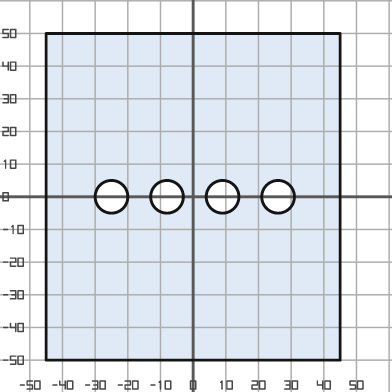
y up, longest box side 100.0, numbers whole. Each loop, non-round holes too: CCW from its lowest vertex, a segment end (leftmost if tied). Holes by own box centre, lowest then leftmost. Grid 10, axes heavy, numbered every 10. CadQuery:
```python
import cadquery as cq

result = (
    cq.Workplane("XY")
    .moveTo(-45.0, -50.0)
    .lineTo(45.0, -50.0)
    .lineTo(45.0, 50.0)
    .lineTo(-45.0, 50.0)
    .close()
    .moveTo(-25.0, 0.0)
    .circle(5.0)
    .moveTo(-8.0, 0.0)
    .circle(5.0)
    .moveTo(9.0, 0.0)
    .circle(5.0)
    .moveTo(26.0, 0.0)
    .circle(5.0)
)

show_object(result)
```